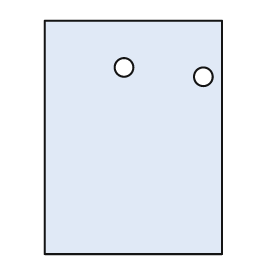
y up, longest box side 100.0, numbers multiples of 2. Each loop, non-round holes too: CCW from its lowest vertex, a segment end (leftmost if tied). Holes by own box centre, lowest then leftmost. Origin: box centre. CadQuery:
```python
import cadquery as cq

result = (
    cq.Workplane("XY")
    .moveTo(-38.0, -50.0)
    .lineTo(38.0, -50.0)
    .lineTo(38.0, 50.0)
    .lineTo(-38.0, 50.0)
    .close()
    .moveTo(30.0, 26.0)
    .circle(4.0)
    .moveTo(-4.0, 30.0)
    .circle(4.0)
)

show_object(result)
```